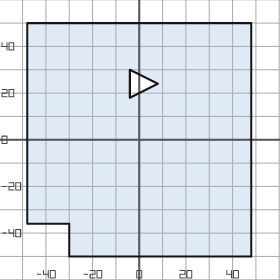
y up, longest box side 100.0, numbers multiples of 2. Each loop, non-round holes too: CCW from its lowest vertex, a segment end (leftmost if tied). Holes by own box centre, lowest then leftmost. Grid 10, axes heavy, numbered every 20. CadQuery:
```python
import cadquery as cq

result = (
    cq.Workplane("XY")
    .moveTo(-30.0, -50.0)
    .lineTo(48.0, -50.0)
    .lineTo(48.0, 50.0)
    .lineTo(-48.0, 50.0)
    .lineTo(-48.0, -36.0)
    .lineTo(-30.0, -36.0)
    .close()
    .moveTo(-4.0, 18.0)
    .lineTo(8.0, 24.0)
    .lineTo(-4.0, 30.0)
    .close()
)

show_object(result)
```